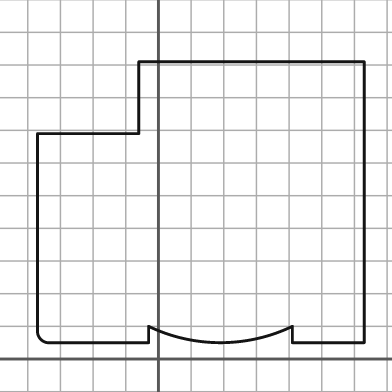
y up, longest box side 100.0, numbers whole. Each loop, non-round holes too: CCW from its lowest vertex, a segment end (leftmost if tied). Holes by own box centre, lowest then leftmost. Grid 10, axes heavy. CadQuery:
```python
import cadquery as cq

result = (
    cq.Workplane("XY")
    .moveTo(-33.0, 5.0)
    .lineTo(-3.0, 5.0)
    .lineTo(-3.0, 10.0)
    .threePointArc((19.0, 5.0), (41.0, 10.0))
    .lineTo(41.0, 5.0)
    .lineTo(63.0, 5.0)
    .lineTo(63.0, 91.0)
    .lineTo(-6.0, 91.0)
    .lineTo(-6.0, 69.0)
    .lineTo(-37.0, 69.0)
    .lineTo(-37.0, 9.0)
    .threePointArc((-36.0, 6.0), (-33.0, 5.0))
    .close()
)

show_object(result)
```